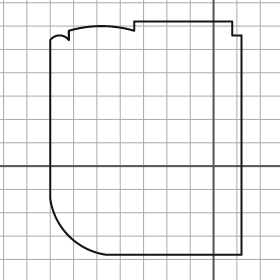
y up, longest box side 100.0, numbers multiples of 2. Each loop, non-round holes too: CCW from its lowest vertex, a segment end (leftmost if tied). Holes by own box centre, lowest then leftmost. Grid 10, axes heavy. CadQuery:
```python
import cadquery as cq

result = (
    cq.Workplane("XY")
    .moveTo(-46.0, -38.0)
    .lineTo(12.0, -38.0)
    .lineTo(12.0, 56.0)
    .lineTo(8.0, 56.0)
    .lineTo(8.0, 62.0)
    .lineTo(-34.0, 62.0)
    .lineTo(-34.0, 58.0)
    .threePointArc((-48.0, 60.0), (-62.0, 58.0))
    .lineTo(-62.0, 54.0)
    .threePointArc((-66.0, 56.0), (-70.0, 54.0))
    .lineTo(-70.0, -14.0)
    .threePointArc((-62.0, -30.0), (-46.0, -38.0))
    .close()
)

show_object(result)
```